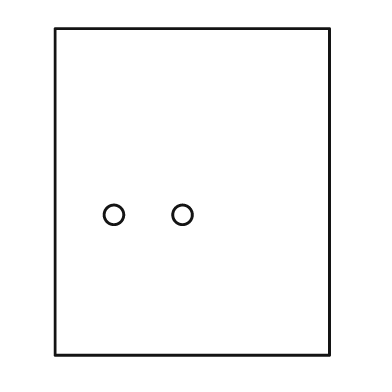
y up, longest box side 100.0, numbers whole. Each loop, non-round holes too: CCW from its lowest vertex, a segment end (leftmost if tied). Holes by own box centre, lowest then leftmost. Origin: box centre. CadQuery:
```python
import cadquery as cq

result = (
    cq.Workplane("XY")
    .moveTo(-42.0, -50.0)
    .lineTo(42.0, -50.0)
    .lineTo(42.0, 50.0)
    .lineTo(-42.0, 50.0)
    .close()
    .moveTo(-24.0, -7.0)
    .circle(3.0)
    .moveTo(-3.0, -7.0)
    .circle(3.0)
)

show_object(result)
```